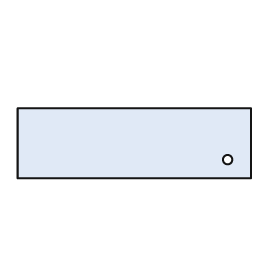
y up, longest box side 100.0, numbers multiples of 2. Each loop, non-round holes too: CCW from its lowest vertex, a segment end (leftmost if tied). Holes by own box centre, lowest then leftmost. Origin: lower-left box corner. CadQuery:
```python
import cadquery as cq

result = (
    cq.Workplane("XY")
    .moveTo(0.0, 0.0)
    .lineTo(100.0, 0.0)
    .lineTo(100.0, 30.0)
    .lineTo(0.0, 30.0)
    .close()
    .moveTo(90.0, 8.0)
    .circle(2.0)
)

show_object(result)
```